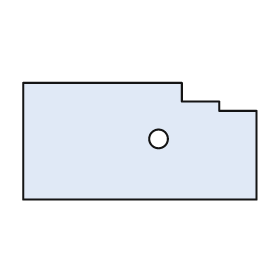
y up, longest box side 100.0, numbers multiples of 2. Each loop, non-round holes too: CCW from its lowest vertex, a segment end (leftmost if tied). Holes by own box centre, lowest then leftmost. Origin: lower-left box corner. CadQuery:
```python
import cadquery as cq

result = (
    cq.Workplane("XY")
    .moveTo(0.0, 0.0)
    .lineTo(100.0, 0.0)
    .lineTo(100.0, 38.0)
    .lineTo(84.0, 38.0)
    .lineTo(84.0, 42.0)
    .lineTo(68.0, 42.0)
    .lineTo(68.0, 50.0)
    .lineTo(0.0, 50.0)
    .close()
    .moveTo(58.0, 26.0)
    .circle(4.0)
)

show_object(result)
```